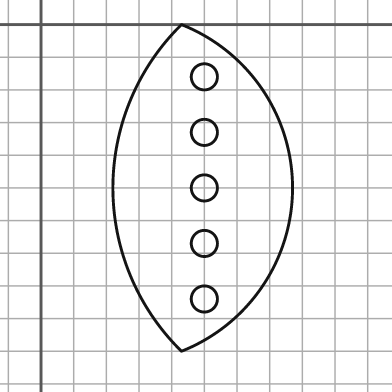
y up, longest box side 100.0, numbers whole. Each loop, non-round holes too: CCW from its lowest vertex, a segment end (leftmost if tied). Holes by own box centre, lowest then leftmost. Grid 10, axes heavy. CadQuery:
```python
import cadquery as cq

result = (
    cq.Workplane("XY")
    .moveTo(43.0, -100.0)
    .threePointArc((77.0, -50.0), (43.0, 0.0))
    .threePointArc((22.0, -50.0), (43.0, -100.0))
    .close()
    .moveTo(50.0, -84.0)
    .circle(4.0)
    .moveTo(50.0, -67.0)
    .circle(4.0)
    .moveTo(50.0, -50.0)
    .circle(4.0)
    .moveTo(50.0, -33.0)
    .circle(4.0)
    .moveTo(50.0, -16.0)
    .circle(4.0)
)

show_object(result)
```